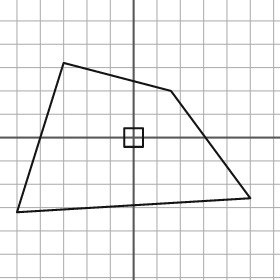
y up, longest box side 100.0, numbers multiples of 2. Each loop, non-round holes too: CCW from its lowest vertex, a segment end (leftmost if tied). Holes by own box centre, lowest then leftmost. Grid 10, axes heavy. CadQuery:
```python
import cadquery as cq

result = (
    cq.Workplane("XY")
    .moveTo(-50.0, -32.0)
    .lineTo(50.0, -26.0)
    .lineTo(16.0, 20.0)
    .lineTo(-30.0, 32.0)
    .close()
    .moveTo(-4.0, -4.0)
    .lineTo(4.0, -4.0)
    .lineTo(4.0, 4.0)
    .lineTo(-4.0, 4.0)
    .close()
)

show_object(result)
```